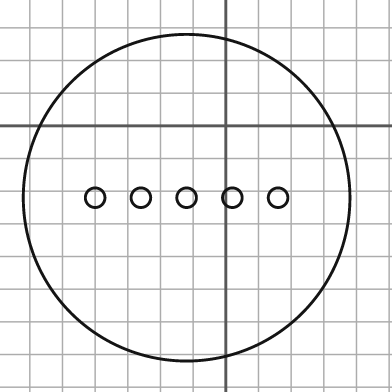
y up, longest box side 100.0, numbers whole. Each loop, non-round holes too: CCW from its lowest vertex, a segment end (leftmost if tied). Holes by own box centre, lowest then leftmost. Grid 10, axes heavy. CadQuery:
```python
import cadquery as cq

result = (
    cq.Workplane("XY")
    .moveTo(-12.0, -22.0)
    .circle(50.0)
    .moveTo(-40.0, -22.0)
    .circle(3.0)
    .moveTo(-26.0, -22.0)
    .circle(3.0)
    .moveTo(-12.0, -22.0)
    .circle(3.0)
    .moveTo(2.0, -22.0)
    .circle(3.0)
    .moveTo(16.0, -22.0)
    .circle(3.0)
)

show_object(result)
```